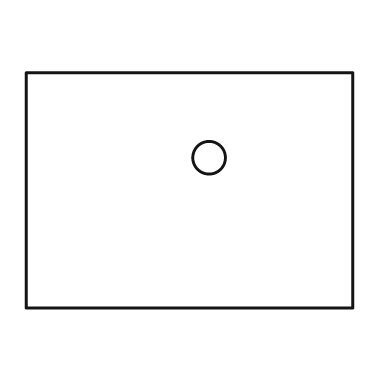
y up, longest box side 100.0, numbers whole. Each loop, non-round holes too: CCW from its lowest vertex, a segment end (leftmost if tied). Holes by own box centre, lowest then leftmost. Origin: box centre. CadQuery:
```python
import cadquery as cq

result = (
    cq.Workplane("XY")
    .moveTo(-50.0, -36.0)
    .lineTo(50.0, -36.0)
    .lineTo(50.0, 36.0)
    .lineTo(-50.0, 36.0)
    .close()
    .moveTo(6.0, 10.0)
    .circle(5.0)
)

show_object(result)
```